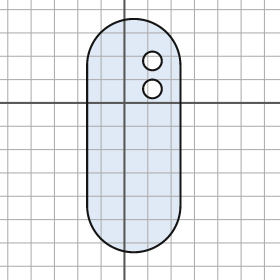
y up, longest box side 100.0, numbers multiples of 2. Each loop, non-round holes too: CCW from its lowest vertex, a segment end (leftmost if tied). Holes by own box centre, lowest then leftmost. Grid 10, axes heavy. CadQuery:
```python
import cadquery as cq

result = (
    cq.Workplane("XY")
    .moveTo(-16.0, -44.0)
    .threePointArc((4.0, -64.0), (24.0, -44.0))
    .lineTo(24.0, 16.0)
    .threePointArc((4.0, 36.0), (-16.0, 16.0))
    .close()
    .moveTo(12.0, 6.0)
    .circle(4.0)
    .moveTo(12.0, 18.0)
    .circle(4.0)
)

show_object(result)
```